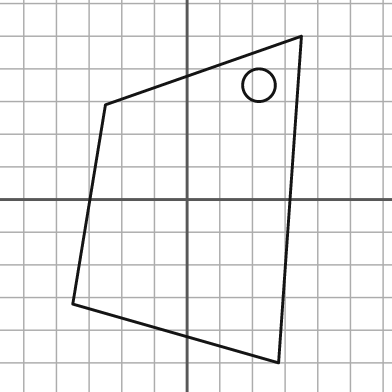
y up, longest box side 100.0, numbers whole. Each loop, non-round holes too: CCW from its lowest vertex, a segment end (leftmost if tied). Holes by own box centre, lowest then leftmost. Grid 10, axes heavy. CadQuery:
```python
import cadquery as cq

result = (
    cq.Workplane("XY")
    .moveTo(28.0, -50.0)
    .lineTo(35.0, 50.0)
    .lineTo(-25.0, 29.0)
    .lineTo(-35.0, -32.0)
    .close()
    .moveTo(22.0, 35.0)
    .circle(5.0)
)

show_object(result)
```